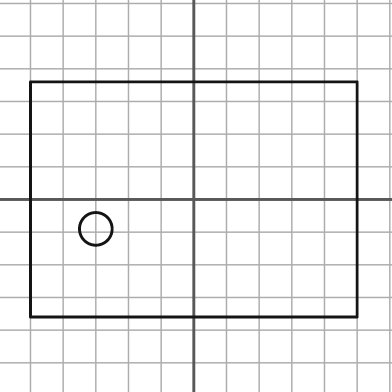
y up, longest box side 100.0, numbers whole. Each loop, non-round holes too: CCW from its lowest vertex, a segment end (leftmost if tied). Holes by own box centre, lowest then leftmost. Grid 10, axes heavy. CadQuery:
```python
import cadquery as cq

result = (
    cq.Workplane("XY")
    .moveTo(-50.0, -36.0)
    .lineTo(50.0, -36.0)
    .lineTo(50.0, 36.0)
    .lineTo(-50.0, 36.0)
    .close()
    .moveTo(-30.0, -9.0)
    .circle(5.0)
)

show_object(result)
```